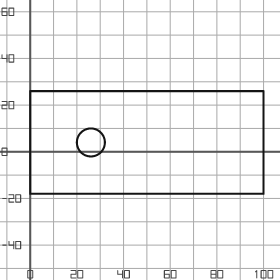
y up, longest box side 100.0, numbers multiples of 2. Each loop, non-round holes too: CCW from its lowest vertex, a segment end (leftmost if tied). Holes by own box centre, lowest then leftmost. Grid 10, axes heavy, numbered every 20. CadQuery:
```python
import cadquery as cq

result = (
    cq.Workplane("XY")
    .moveTo(0.0, -18.0)
    .lineTo(100.0, -18.0)
    .lineTo(100.0, 26.0)
    .lineTo(0.0, 26.0)
    .close()
    .moveTo(26.0, 4.0)
    .circle(6.0)
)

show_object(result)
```